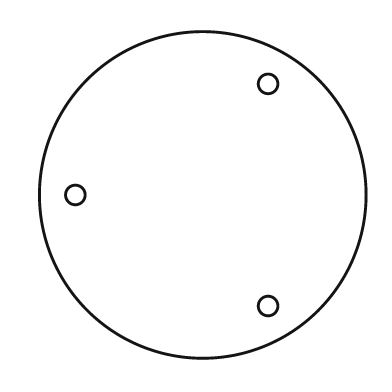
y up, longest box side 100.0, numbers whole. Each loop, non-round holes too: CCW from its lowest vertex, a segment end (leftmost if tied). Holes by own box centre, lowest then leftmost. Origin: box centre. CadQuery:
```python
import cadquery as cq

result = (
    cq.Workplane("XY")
    .moveTo(0.0, 0.0)
    .circle(50.0)
    .moveTo(20.0, -34.0)
    .circle(3.0)
    .moveTo(-39.0, 0.0)
    .circle(3.0)
    .moveTo(20.0, 34.0)
    .circle(3.0)
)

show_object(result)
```